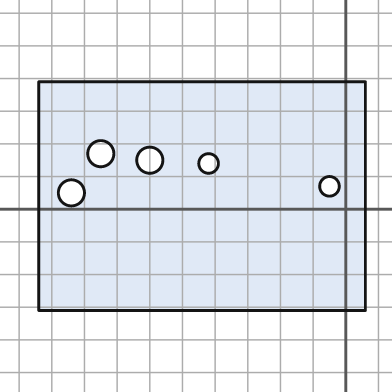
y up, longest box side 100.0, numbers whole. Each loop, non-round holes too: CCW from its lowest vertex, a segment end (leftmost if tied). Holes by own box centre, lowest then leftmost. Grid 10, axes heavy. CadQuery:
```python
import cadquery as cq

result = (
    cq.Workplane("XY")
    .moveTo(-94.0, -31.0)
    .lineTo(6.0, -31.0)
    .lineTo(6.0, 39.0)
    .lineTo(-94.0, 39.0)
    .close()
    .moveTo(-84.0, 5.0)
    .circle(4.0)
    .moveTo(-5.0, 7.0)
    .circle(3.0)
    .moveTo(-42.0, 14.0)
    .circle(3.0)
    .moveTo(-60.0, 15.0)
    .circle(4.0)
    .moveTo(-75.0, 17.0)
    .circle(4.0)
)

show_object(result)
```